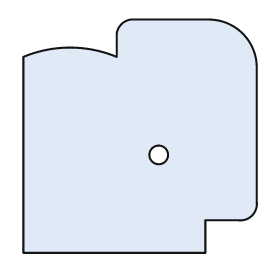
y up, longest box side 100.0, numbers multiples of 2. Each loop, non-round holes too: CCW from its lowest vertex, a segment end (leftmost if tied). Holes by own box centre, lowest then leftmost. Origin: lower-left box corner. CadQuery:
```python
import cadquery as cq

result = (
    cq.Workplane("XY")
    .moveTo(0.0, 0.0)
    .lineTo(78.0, 0.0)
    .lineTo(78.0, 14.0)
    .lineTo(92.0, 14.0)
    .threePointArc((98.0, 16.0), (100.0, 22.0))
    .lineTo(100.0, 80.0)
    .threePointArc((94.0, 94.0), (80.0, 100.0))
    .lineTo(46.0, 100.0)
    .threePointArc((42.0, 98.0), (40.0, 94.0))
    .lineTo(40.0, 84.0)
    .threePointArc((20.0, 88.0), (0.0, 84.0))
    .close()
    .moveTo(58.0, 42.0)
    .circle(4.0)
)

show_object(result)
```